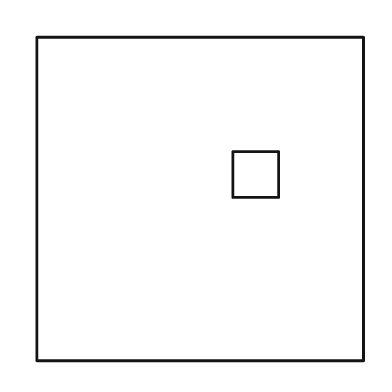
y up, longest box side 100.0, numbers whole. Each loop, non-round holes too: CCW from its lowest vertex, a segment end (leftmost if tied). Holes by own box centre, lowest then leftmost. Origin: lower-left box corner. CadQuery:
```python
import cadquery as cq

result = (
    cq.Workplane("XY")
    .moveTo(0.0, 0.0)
    .lineTo(100.0, 0.0)
    .lineTo(100.0, 99.0)
    .lineTo(0.0, 99.0)
    .close()
    .moveTo(60.0, 50.0)
    .lineTo(74.0, 50.0)
    .lineTo(74.0, 64.0)
    .lineTo(60.0, 64.0)
    .close()
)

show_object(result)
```